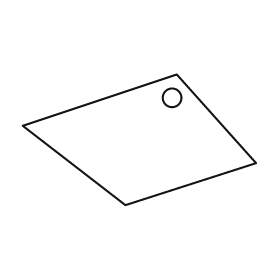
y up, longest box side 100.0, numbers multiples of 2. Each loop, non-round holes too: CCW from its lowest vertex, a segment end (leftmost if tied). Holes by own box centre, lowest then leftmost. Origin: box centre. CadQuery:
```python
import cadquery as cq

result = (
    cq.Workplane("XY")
    .moveTo(-6.0, -28.0)
    .lineTo(50.0, -10.0)
    .lineTo(16.0, 28.0)
    .lineTo(-50.0, 6.0)
    .close()
    .moveTo(14.0, 18.0)
    .circle(4.0)
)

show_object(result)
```